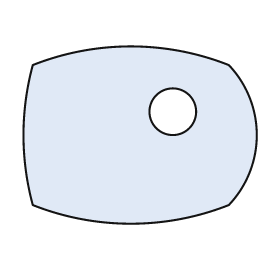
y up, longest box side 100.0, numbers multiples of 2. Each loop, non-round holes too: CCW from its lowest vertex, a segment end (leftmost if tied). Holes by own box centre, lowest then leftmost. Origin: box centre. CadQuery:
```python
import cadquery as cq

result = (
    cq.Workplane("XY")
    .moveTo(-46.0, -30.0)
    .threePointArc((-4.0, -38.0), (38.0, -30.0))
    .threePointArc((50.0, 0.0), (38.0, 30.0))
    .threePointArc((-4.0, 38.0), (-46.0, 30.0))
    .threePointArc((-50.0, 0.0), (-46.0, -30.0))
    .close()
    .moveTo(14.0, 10.0)
    .circle(10.0)
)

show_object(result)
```